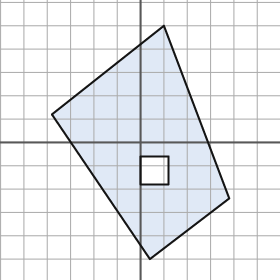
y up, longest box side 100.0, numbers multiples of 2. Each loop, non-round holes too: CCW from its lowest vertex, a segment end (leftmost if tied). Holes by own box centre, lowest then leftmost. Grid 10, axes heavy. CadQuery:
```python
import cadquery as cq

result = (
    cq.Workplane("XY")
    .moveTo(4.0, -50.0)
    .lineTo(38.0, -24.0)
    .lineTo(10.0, 50.0)
    .lineTo(-38.0, 12.0)
    .close()
    .moveTo(0.0, -18.0)
    .lineTo(12.0, -18.0)
    .lineTo(12.0, -6.0)
    .lineTo(0.0, -6.0)
    .close()
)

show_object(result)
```